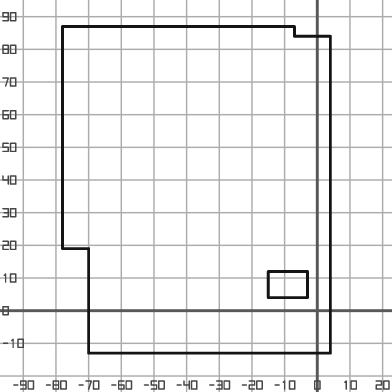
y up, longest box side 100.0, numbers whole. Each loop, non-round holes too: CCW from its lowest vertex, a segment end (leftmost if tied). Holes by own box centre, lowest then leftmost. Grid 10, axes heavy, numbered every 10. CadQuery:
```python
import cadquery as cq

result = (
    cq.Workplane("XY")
    .moveTo(-70.0, -13.0)
    .lineTo(4.0, -13.0)
    .lineTo(4.0, 84.0)
    .lineTo(-7.0, 84.0)
    .lineTo(-7.0, 87.0)
    .lineTo(-78.0, 87.0)
    .lineTo(-78.0, 19.0)
    .lineTo(-70.0, 19.0)
    .close()
    .moveTo(-15.0, 4.0)
    .lineTo(-3.0, 4.0)
    .lineTo(-3.0, 12.0)
    .lineTo(-15.0, 12.0)
    .close()
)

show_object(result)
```